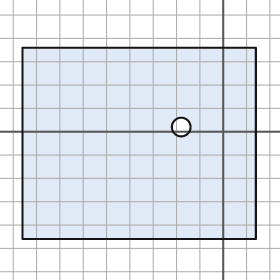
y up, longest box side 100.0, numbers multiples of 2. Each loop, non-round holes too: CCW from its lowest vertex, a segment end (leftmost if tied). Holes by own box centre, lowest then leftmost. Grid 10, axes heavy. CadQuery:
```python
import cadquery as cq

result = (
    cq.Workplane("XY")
    .moveTo(-86.0, -46.0)
    .lineTo(14.0, -46.0)
    .lineTo(14.0, 36.0)
    .lineTo(-86.0, 36.0)
    .close()
    .moveTo(-18.0, 2.0)
    .circle(4.0)
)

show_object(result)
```